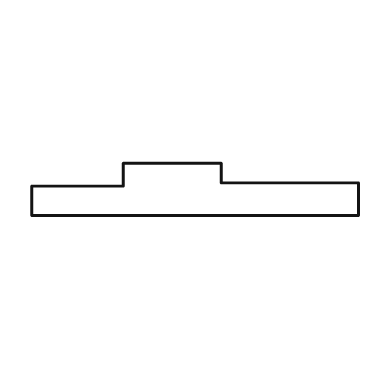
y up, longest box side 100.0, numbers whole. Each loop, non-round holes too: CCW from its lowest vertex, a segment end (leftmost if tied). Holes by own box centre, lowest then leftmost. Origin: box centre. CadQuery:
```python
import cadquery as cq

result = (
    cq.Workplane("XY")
    .moveTo(-50.0, -8.0)
    .lineTo(50.0, -8.0)
    .lineTo(50.0, 2.0)
    .lineTo(8.0, 2.0)
    .lineTo(8.0, 8.0)
    .lineTo(-22.0, 8.0)
    .lineTo(-22.0, 1.0)
    .lineTo(-50.0, 1.0)
    .close()
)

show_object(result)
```